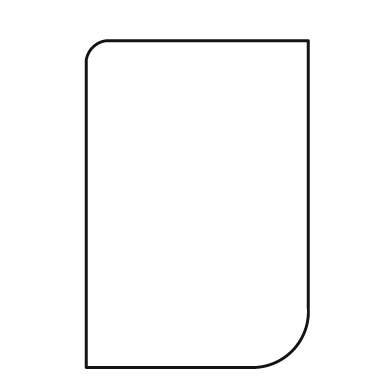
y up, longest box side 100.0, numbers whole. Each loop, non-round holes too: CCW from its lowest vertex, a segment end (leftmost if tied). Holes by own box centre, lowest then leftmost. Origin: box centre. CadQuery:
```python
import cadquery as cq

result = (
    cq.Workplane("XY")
    .moveTo(-34.0, -50.0)
    .lineTo(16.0, -50.0)
    .threePointArc((29.0, -45.0), (34.0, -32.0))
    .lineTo(34.0, 50.0)
    .lineTo(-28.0, 50.0)
    .threePointArc((-32.0, 48.0), (-34.0, 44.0))
    .close()
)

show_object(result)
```